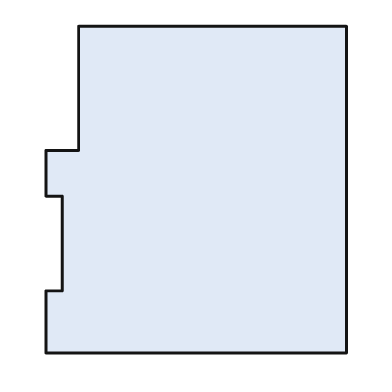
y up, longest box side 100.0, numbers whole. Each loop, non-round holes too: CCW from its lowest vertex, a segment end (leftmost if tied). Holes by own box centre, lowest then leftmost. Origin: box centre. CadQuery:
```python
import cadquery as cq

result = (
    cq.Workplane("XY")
    .moveTo(-46.0, -50.0)
    .lineTo(46.0, -50.0)
    .lineTo(46.0, 50.0)
    .lineTo(-36.0, 50.0)
    .lineTo(-36.0, 12.0)
    .lineTo(-46.0, 12.0)
    .lineTo(-46.0, -2.0)
    .lineTo(-41.0, -2.0)
    .lineTo(-41.0, -31.0)
    .lineTo(-46.0, -31.0)
    .close()
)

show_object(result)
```